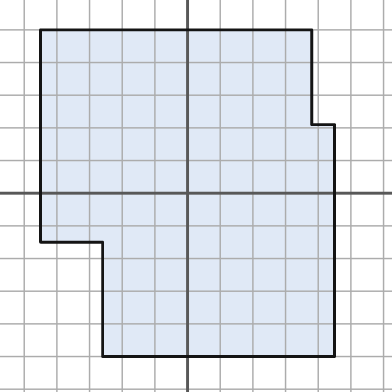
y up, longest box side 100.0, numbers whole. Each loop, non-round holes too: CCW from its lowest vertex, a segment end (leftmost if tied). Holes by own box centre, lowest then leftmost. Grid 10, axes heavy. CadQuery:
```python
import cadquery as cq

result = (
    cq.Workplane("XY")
    .moveTo(-26.0, -50.0)
    .lineTo(45.0, -50.0)
    .lineTo(45.0, 21.0)
    .lineTo(38.0, 21.0)
    .lineTo(38.0, 50.0)
    .lineTo(-45.0, 50.0)
    .lineTo(-45.0, -15.0)
    .lineTo(-26.0, -15.0)
    .close()
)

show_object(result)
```